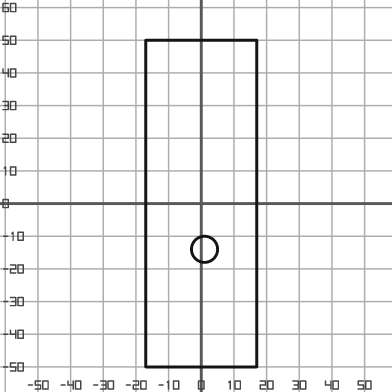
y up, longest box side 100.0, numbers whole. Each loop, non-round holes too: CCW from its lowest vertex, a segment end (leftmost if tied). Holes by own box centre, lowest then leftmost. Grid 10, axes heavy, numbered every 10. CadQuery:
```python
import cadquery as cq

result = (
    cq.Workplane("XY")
    .moveTo(-17.0, -50.0)
    .lineTo(17.0, -50.0)
    .lineTo(17.0, 50.0)
    .lineTo(-17.0, 50.0)
    .close()
    .moveTo(1.0, -14.0)
    .circle(4.0)
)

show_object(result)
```